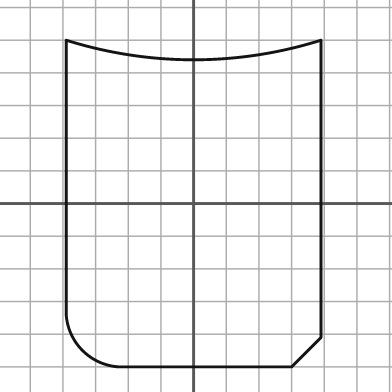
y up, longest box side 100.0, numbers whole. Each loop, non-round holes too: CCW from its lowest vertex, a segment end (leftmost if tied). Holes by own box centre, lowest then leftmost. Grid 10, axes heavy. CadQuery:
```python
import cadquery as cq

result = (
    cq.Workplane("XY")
    .moveTo(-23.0, -50.0)
    .lineTo(30.0, -50.0)
    .lineTo(39.0, -41.0)
    .lineTo(39.0, 50.0)
    .threePointArc((0.0, 44.0), (-39.0, 50.0))
    .lineTo(-39.0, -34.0)
    .threePointArc((-34.0, -45.0), (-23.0, -50.0))
    .close()
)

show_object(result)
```